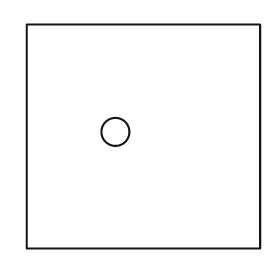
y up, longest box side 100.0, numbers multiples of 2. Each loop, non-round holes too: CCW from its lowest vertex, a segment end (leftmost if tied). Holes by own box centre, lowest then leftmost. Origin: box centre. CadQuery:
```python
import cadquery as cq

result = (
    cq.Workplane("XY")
    .moveTo(-50.0, -48.0)
    .lineTo(50.0, -48.0)
    .lineTo(50.0, 48.0)
    .lineTo(-50.0, 48.0)
    .close()
    .moveTo(-12.0, 2.0)
    .circle(6.0)
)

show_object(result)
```